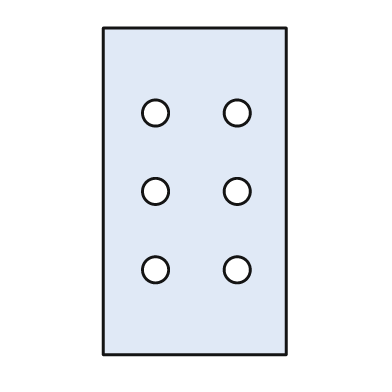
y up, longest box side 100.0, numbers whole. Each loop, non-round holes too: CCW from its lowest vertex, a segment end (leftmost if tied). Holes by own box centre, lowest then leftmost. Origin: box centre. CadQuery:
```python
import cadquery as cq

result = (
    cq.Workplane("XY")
    .moveTo(-28.0, -50.0)
    .lineTo(28.0, -50.0)
    .lineTo(28.0, 50.0)
    .lineTo(-28.0, 50.0)
    .close()
    .moveTo(-12.0, -24.0)
    .circle(4.0)
    .moveTo(13.0, -24.0)
    .circle(4.0)
    .moveTo(-12.0, 0.0)
    .circle(4.0)
    .moveTo(13.0, 0.0)
    .circle(4.0)
    .moveTo(-12.0, 24.0)
    .circle(4.0)
    .moveTo(13.0, 24.0)
    .circle(4.0)
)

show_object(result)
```